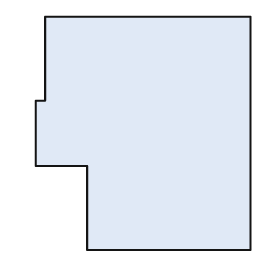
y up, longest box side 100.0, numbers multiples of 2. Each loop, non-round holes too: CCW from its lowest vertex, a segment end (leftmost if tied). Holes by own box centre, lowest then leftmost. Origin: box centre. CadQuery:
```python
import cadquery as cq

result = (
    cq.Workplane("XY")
    .moveTo(-24.0, -50.0)
    .lineTo(46.0, -50.0)
    .lineTo(46.0, 50.0)
    .lineTo(-42.0, 50.0)
    .lineTo(-42.0, 14.0)
    .lineTo(-46.0, 14.0)
    .lineTo(-46.0, -14.0)
    .lineTo(-24.0, -14.0)
    .close()
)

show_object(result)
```